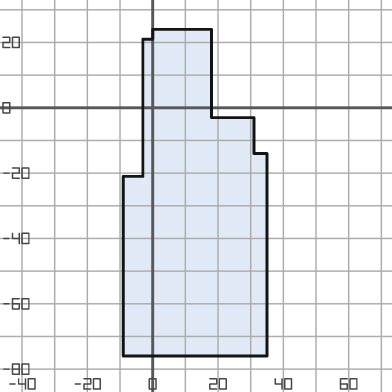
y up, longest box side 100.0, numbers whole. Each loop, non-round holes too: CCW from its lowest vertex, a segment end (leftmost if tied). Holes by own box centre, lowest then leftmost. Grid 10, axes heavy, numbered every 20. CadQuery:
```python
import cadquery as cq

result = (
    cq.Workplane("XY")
    .moveTo(-9.0, -76.0)
    .lineTo(35.0, -76.0)
    .lineTo(35.0, -14.0)
    .lineTo(31.0, -14.0)
    .lineTo(31.0, -3.0)
    .lineTo(18.0, -3.0)
    .lineTo(18.0, 24.0)
    .lineTo(0.0, 24.0)
    .lineTo(0.0, 21.0)
    .lineTo(-3.0, 21.0)
    .lineTo(-3.0, -21.0)
    .lineTo(-9.0, -21.0)
    .close()
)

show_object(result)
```